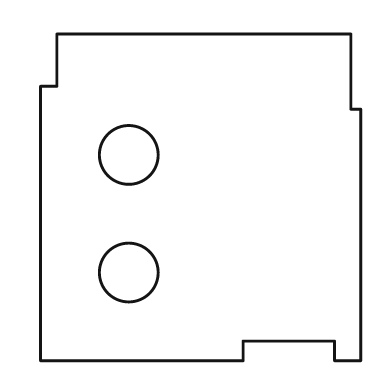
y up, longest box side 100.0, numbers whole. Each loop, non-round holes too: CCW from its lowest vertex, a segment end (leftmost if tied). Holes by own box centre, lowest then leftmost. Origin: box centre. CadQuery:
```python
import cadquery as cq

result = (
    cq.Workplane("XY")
    .moveTo(-49.0, -50.0)
    .lineTo(13.0, -50.0)
    .lineTo(13.0, -44.0)
    .lineTo(41.0, -44.0)
    .lineTo(41.0, -50.0)
    .lineTo(49.0, -50.0)
    .lineTo(49.0, 27.0)
    .lineTo(46.0, 27.0)
    .lineTo(46.0, 50.0)
    .lineTo(-44.0, 50.0)
    .lineTo(-44.0, 34.0)
    .lineTo(-49.0, 34.0)
    .close()
    .moveTo(-22.0, -23.0)
    .circle(9.0)
    .moveTo(-22.0, 13.0)
    .circle(9.0)
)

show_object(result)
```